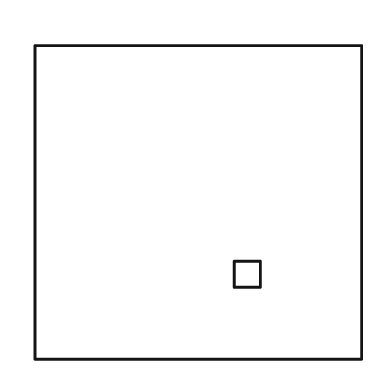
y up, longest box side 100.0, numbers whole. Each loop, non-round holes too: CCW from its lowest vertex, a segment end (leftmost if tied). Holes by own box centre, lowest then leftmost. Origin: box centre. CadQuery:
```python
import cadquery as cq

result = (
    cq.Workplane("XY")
    .moveTo(-50.0, -48.0)
    .lineTo(50.0, -48.0)
    .lineTo(50.0, 48.0)
    .lineTo(-50.0, 48.0)
    .close()
    .moveTo(11.0, -26.0)
    .lineTo(19.0, -26.0)
    .lineTo(19.0, -18.0)
    .lineTo(11.0, -18.0)
    .close()
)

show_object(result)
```